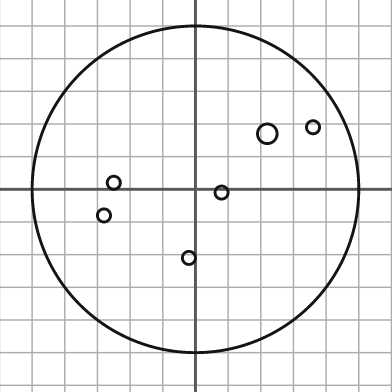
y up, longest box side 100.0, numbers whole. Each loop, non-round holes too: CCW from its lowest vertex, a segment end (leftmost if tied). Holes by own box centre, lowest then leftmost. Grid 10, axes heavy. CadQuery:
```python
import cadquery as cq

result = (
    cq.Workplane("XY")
    .moveTo(0.0, 0.0)
    .circle(50.0)
    .moveTo(-2.0, -21.0)
    .circle(2.0)
    .moveTo(-28.0, -8.0)
    .circle(2.0)
    .moveTo(8.0, -1.0)
    .circle(2.0)
    .moveTo(-25.0, 2.0)
    .circle(2.0)
    .moveTo(22.0, 17.0)
    .circle(3.0)
    .moveTo(36.0, 19.0)
    .circle(2.0)
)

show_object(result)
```